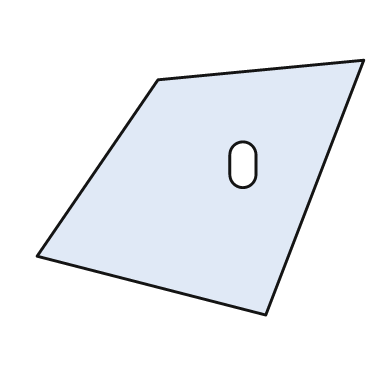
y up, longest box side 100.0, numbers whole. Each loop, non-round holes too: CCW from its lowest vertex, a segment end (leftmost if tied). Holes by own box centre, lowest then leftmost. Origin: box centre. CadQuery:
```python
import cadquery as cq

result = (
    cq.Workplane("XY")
    .moveTo(20.0, -39.0)
    .lineTo(50.0, 39.0)
    .lineTo(-13.0, 33.0)
    .lineTo(-50.0, -21.0)
    .close()
    .moveTo(9.0, 4.0)
    .threePointArc((13.0, 0.0), (17.0, 4.0))
    .lineTo(17.0, 10.0)
    .threePointArc((13.0, 14.0), (9.0, 10.0))
    .close()
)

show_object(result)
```